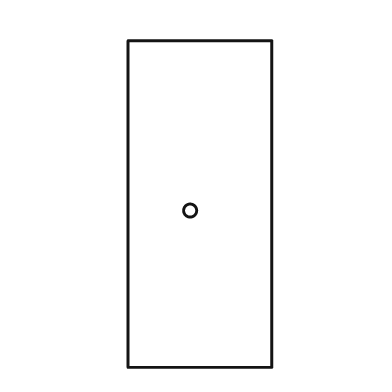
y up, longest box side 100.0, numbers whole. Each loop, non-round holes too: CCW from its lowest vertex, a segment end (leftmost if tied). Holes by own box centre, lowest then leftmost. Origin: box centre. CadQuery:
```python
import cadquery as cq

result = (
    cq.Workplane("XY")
    .moveTo(-22.0, -50.0)
    .lineTo(22.0, -50.0)
    .lineTo(22.0, 50.0)
    .lineTo(-22.0, 50.0)
    .close()
    .moveTo(-3.0, -2.0)
    .circle(2.0)
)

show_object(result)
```